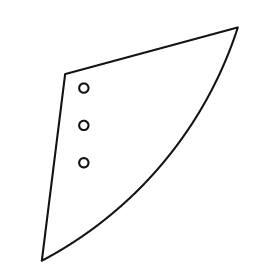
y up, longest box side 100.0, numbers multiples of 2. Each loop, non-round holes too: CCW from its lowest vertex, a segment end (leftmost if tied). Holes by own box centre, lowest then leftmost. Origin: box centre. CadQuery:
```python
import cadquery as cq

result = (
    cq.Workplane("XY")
    .moveTo(-42.0, -50.0)
    .threePointArc((10.0, -8.0), (42.0, 50.0))
    .lineTo(-32.0, 30.0)
    .close()
    .moveTo(-24.0, -8.0)
    .circle(2.0)
    .moveTo(-24.0, 8.0)
    .circle(2.0)
    .moveTo(-24.0, 24.0)
    .circle(2.0)
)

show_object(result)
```